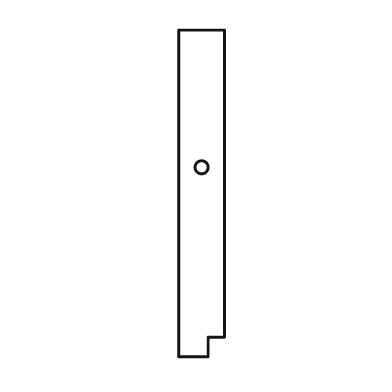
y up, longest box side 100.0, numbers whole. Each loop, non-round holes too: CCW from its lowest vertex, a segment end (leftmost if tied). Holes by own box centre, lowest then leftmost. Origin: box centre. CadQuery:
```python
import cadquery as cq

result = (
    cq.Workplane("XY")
    .moveTo(-7.0, -50.0)
    .lineTo(2.0, -50.0)
    .lineTo(2.0, -44.0)
    .lineTo(7.0, -44.0)
    .lineTo(7.0, 50.0)
    .lineTo(-7.0, 50.0)
    .close()
    .moveTo(0.0, 8.0)
    .circle(2.0)
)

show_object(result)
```